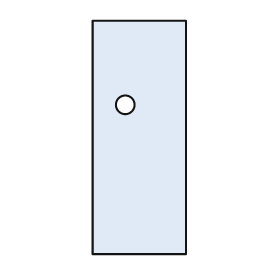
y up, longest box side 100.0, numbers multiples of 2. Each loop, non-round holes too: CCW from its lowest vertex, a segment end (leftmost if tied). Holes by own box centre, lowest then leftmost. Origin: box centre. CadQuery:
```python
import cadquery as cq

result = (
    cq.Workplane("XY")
    .moveTo(-20.0, -50.0)
    .lineTo(20.0, -50.0)
    .lineTo(20.0, 50.0)
    .lineTo(-20.0, 50.0)
    .close()
    .moveTo(-6.0, 14.0)
    .circle(4.0)
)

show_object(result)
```